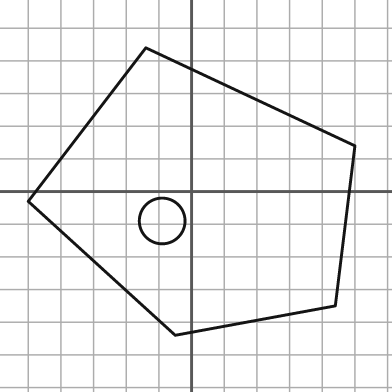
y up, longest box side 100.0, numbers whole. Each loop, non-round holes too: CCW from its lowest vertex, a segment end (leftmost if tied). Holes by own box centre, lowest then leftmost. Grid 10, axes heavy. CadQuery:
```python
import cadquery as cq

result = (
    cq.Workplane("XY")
    .moveTo(-5.0, -44.0)
    .lineTo(44.0, -35.0)
    .lineTo(50.0, 14.0)
    .lineTo(-14.0, 44.0)
    .lineTo(-50.0, -3.0)
    .close()
    .moveTo(-9.0, -9.0)
    .circle(7.0)
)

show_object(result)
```